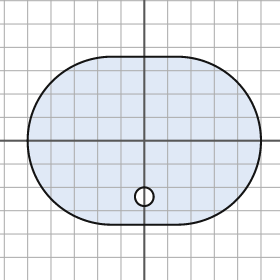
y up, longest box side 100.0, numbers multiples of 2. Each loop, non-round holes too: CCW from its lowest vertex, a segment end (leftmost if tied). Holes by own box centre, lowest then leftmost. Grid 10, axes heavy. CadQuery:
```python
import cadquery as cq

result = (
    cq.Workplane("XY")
    .moveTo(-14.0, -36.0)
    .lineTo(14.0, -36.0)
    .threePointArc((50.0, 0.0), (14.0, 36.0))
    .lineTo(-14.0, 36.0)
    .threePointArc((-50.0, 0.0), (-14.0, -36.0))
    .close()
    .moveTo(0.0, -24.0)
    .circle(4.0)
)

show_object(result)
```